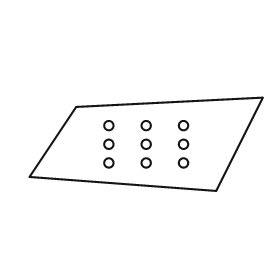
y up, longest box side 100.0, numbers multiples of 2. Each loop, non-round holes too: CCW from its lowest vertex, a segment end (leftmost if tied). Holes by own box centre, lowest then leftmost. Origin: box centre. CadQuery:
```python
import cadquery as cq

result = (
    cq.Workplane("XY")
    .moveTo(30.0, -20.0)
    .lineTo(50.0, 20.0)
    .lineTo(-30.0, 16.0)
    .lineTo(-50.0, -14.0)
    .close()
    .moveTo(-16.0, -8.0)
    .circle(2.0)
    .moveTo(0.0, -8.0)
    .circle(2.0)
    .moveTo(16.0, -8.0)
    .circle(2.0)
    .moveTo(-16.0, 0.0)
    .circle(2.0)
    .moveTo(0.0, 0.0)
    .circle(2.0)
    .moveTo(16.0, 0.0)
    .circle(2.0)
    .moveTo(-16.0, 8.0)
    .circle(2.0)
    .moveTo(0.0, 8.0)
    .circle(2.0)
    .moveTo(16.0, 8.0)
    .circle(2.0)
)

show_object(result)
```